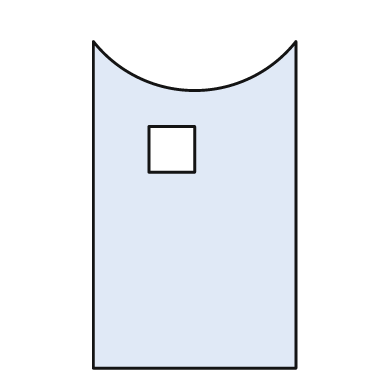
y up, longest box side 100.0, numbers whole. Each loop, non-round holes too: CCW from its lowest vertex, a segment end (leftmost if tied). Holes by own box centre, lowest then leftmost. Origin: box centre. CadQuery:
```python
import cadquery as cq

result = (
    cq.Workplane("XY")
    .moveTo(-31.0, -50.0)
    .lineTo(31.0, -50.0)
    .lineTo(31.0, 50.0)
    .threePointArc((0.0, 35.0), (-31.0, 50.0))
    .close()
    .moveTo(-14.0, 10.0)
    .lineTo(0.0, 10.0)
    .lineTo(0.0, 24.0)
    .lineTo(-14.0, 24.0)
    .close()
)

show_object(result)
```